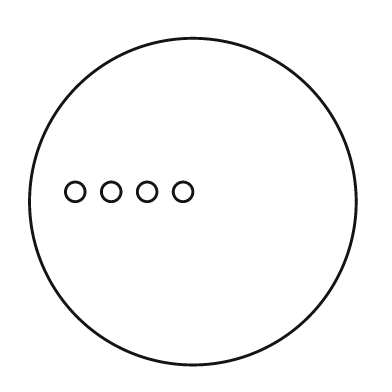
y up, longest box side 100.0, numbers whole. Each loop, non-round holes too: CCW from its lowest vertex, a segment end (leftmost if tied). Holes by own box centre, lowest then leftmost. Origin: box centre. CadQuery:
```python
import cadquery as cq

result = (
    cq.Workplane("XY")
    .moveTo(0.0, 0.0)
    .circle(50.0)
    .moveTo(-36.0, 3.0)
    .circle(3.0)
    .moveTo(-25.0, 3.0)
    .circle(3.0)
    .moveTo(-14.0, 3.0)
    .circle(3.0)
    .moveTo(-3.0, 3.0)
    .circle(3.0)
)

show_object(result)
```